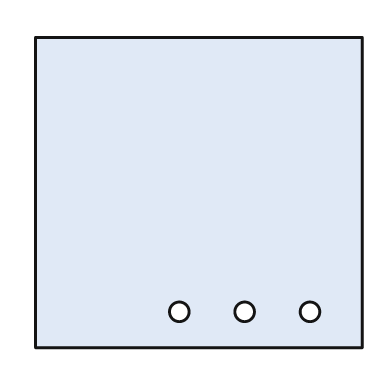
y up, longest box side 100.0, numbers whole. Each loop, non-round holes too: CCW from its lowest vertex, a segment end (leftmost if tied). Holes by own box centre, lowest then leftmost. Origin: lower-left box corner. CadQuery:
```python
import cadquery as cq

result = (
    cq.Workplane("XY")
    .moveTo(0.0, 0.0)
    .lineTo(100.0, 0.0)
    .lineTo(100.0, 95.0)
    .lineTo(0.0, 95.0)
    .close()
    .moveTo(44.0, 11.0)
    .circle(3.0)
    .moveTo(64.0, 11.0)
    .circle(3.0)
    .moveTo(84.0, 11.0)
    .circle(3.0)
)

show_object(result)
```